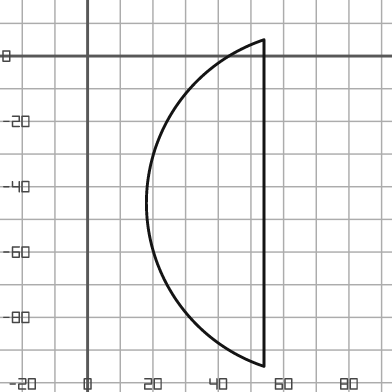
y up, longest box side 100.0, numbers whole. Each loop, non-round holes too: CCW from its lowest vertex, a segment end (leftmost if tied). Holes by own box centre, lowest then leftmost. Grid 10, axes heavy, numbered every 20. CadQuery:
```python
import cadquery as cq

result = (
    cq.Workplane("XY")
    .moveTo(54.0, -95.0)
    .lineTo(54.0, 5.0)
    .threePointArc((18.0, -45.0), (54.0, -95.0))
    .close()
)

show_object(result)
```